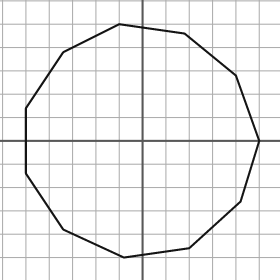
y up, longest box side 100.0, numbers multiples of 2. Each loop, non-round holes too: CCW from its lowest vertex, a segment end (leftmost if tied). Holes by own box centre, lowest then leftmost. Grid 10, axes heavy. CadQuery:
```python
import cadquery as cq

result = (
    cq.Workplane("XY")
    .moveTo(-8.0, -50.0)
    .lineTo(20.0, -46.0)
    .lineTo(42.0, -26.0)
    .lineTo(50.0, 0.0)
    .lineTo(40.0, 28.0)
    .lineTo(18.0, 46.0)
    .lineTo(-10.0, 50.0)
    .lineTo(-34.0, 38.0)
    .lineTo(-50.0, 14.0)
    .lineTo(-50.0, -14.0)
    .lineTo(-34.0, -38.0)
    .close()
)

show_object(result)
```